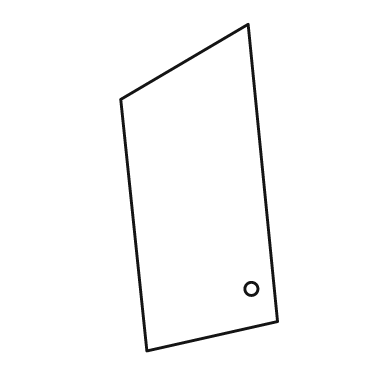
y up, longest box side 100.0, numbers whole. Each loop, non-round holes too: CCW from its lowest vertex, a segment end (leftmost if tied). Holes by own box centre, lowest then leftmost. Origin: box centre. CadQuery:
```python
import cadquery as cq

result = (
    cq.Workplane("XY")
    .moveTo(-16.0, -50.0)
    .lineTo(24.0, -41.0)
    .lineTo(15.0, 50.0)
    .lineTo(-24.0, 27.0)
    .close()
    .moveTo(16.0, -31.0)
    .circle(2.0)
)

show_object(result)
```